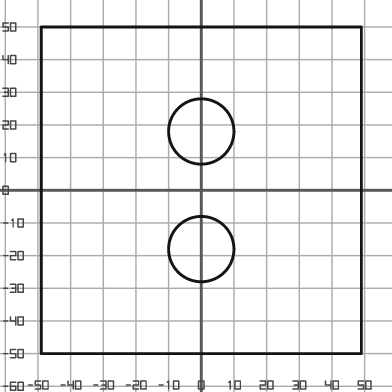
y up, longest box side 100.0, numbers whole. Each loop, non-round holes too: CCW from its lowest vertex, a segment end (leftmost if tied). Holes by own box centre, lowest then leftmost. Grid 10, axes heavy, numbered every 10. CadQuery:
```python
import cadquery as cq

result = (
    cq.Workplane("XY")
    .moveTo(-49.0, -50.0)
    .lineTo(49.0, -50.0)
    .lineTo(49.0, 50.0)
    .lineTo(-49.0, 50.0)
    .close()
    .moveTo(0.0, -18.0)
    .circle(10.0)
    .moveTo(0.0, 18.0)
    .circle(10.0)
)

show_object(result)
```